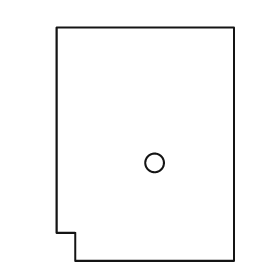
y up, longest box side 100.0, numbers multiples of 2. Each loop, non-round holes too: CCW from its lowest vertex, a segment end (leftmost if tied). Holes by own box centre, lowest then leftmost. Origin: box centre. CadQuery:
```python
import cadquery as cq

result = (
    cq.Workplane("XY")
    .moveTo(-30.0, -50.0)
    .lineTo(38.0, -50.0)
    .lineTo(38.0, 50.0)
    .lineTo(-38.0, 50.0)
    .lineTo(-38.0, -38.0)
    .lineTo(-30.0, -38.0)
    .close()
    .moveTo(4.0, -8.0)
    .circle(4.0)
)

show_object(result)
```